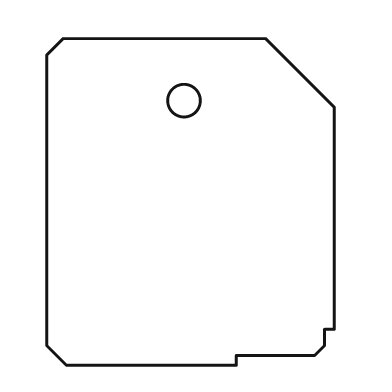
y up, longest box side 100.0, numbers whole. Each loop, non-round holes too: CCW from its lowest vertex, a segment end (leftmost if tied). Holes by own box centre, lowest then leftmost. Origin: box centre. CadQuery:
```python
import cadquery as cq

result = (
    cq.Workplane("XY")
    .moveTo(-38.0, -50.0)
    .lineTo(14.0, -50.0)
    .lineTo(14.0, -47.0)
    .lineTo(38.0, -47.0)
    .lineTo(41.0, -44.0)
    .lineTo(41.0, -39.0)
    .lineTo(44.0, -39.0)
    .lineTo(44.0, 29.0)
    .lineTo(23.0, 50.0)
    .lineTo(-39.0, 50.0)
    .lineTo(-44.0, 45.0)
    .lineTo(-44.0, -44.0)
    .close()
    .moveTo(-2.0, 31.0)
    .circle(5.0)
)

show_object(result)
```